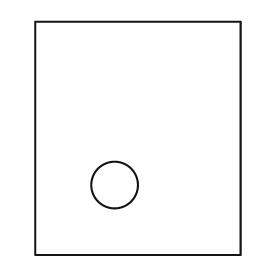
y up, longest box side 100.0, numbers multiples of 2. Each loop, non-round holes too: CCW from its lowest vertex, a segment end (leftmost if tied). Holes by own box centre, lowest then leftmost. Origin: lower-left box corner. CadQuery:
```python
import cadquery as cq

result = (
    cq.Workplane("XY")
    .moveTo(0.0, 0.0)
    .lineTo(88.0, 0.0)
    .lineTo(88.0, 100.0)
    .lineTo(0.0, 100.0)
    .close()
    .moveTo(34.0, 30.0)
    .circle(10.0)
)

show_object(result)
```